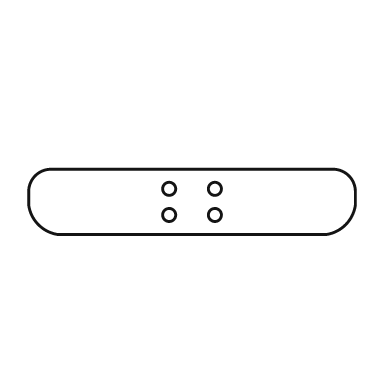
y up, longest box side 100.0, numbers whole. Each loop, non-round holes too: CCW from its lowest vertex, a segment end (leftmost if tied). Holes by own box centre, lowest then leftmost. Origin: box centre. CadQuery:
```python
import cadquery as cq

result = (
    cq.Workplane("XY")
    .moveTo(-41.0, -10.0)
    .lineTo(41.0, -10.0)
    .threePointArc((47.0, -7.0), (50.0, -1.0))
    .lineTo(50.0, 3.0)
    .threePointArc((48.0, 8.0), (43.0, 10.0))
    .lineTo(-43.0, 10.0)
    .threePointArc((-48.0, 8.0), (-50.0, 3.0))
    .lineTo(-50.0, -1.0)
    .threePointArc((-47.0, -7.0), (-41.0, -10.0))
    .close()
    .moveTo(-7.0, -4.0)
    .circle(2.0)
    .moveTo(7.0, -4.0)
    .circle(2.0)
    .moveTo(-7.0, 4.0)
    .circle(2.0)
    .moveTo(7.0, 4.0)
    .circle(2.0)
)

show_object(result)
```